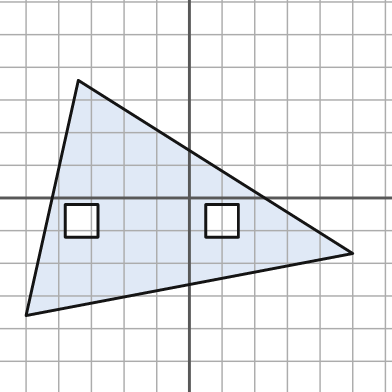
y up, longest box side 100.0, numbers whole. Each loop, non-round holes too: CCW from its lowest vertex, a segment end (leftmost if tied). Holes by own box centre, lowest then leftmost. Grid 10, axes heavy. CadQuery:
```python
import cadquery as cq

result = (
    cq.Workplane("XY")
    .moveTo(-50.0, -36.0)
    .lineTo(50.0, -17.0)
    .lineTo(-34.0, 36.0)
    .close()
    .moveTo(-38.0, -12.0)
    .lineTo(-28.0, -12.0)
    .lineTo(-28.0, -2.0)
    .lineTo(-38.0, -2.0)
    .close()
    .moveTo(5.0, -12.0)
    .lineTo(15.0, -12.0)
    .lineTo(15.0, -2.0)
    .lineTo(5.0, -2.0)
    .close()
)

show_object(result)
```